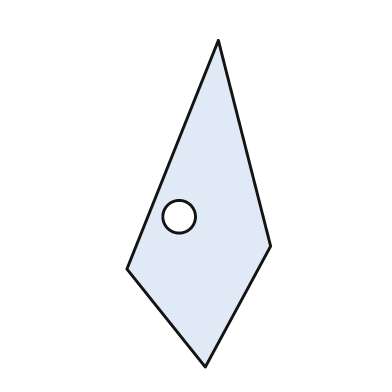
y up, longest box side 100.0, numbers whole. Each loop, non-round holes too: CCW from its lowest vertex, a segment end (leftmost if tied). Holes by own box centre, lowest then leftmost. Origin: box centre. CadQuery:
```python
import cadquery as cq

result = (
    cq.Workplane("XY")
    .moveTo(2.0, -50.0)
    .lineTo(22.0, -13.0)
    .lineTo(6.0, 50.0)
    .lineTo(-22.0, -20.0)
    .close()
    .moveTo(-6.0, -4.0)
    .circle(5.0)
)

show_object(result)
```